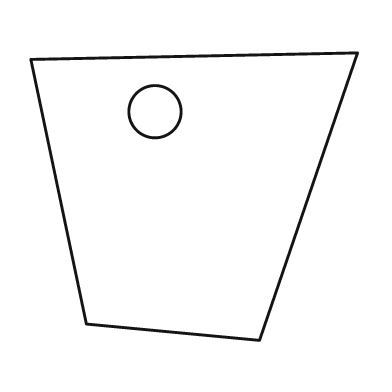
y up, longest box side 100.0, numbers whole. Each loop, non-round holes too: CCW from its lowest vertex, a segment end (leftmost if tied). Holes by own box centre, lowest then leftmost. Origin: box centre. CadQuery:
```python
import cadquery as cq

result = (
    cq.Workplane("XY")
    .moveTo(20.0, -44.0)
    .lineTo(50.0, 44.0)
    .lineTo(-50.0, 42.0)
    .lineTo(-33.0, -39.0)
    .close()
    .moveTo(-12.0, 26.0)
    .circle(8.0)
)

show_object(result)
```